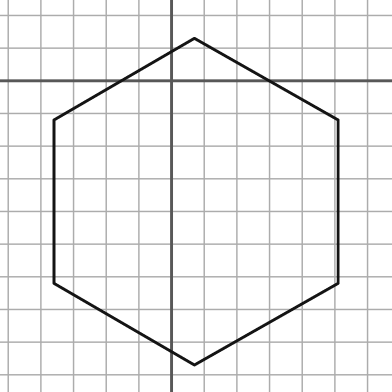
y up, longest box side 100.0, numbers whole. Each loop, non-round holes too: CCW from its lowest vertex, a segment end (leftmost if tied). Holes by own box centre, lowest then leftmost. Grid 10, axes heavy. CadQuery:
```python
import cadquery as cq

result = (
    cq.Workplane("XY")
    .moveTo(7.0, -87.0)
    .lineTo(51.0, -62.0)
    .lineTo(51.0, -12.0)
    .lineTo(7.0, 13.0)
    .lineTo(-36.0, -12.0)
    .lineTo(-36.0, -62.0)
    .close()
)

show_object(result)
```